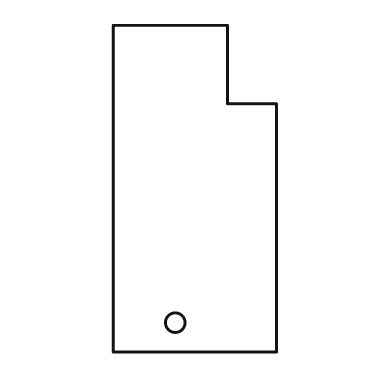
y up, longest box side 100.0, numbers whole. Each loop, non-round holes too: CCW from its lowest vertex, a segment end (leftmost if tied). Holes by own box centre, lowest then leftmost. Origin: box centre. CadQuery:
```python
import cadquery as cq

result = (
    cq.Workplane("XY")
    .moveTo(-25.0, -50.0)
    .lineTo(25.0, -50.0)
    .lineTo(25.0, 26.0)
    .lineTo(10.0, 26.0)
    .lineTo(10.0, 50.0)
    .lineTo(-25.0, 50.0)
    .close()
    .moveTo(-6.0, -41.0)
    .circle(3.0)
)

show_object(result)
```